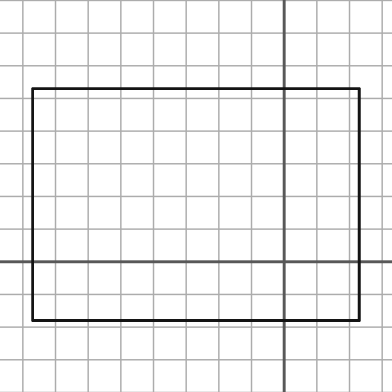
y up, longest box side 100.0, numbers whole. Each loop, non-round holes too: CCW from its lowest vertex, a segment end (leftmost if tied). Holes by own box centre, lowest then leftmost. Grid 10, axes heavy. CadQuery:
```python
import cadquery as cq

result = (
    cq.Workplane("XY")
    .moveTo(-77.0, -18.0)
    .lineTo(23.0, -18.0)
    .lineTo(23.0, 53.0)
    .lineTo(-77.0, 53.0)
    .close()
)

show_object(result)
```